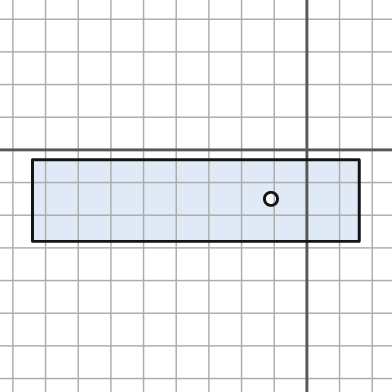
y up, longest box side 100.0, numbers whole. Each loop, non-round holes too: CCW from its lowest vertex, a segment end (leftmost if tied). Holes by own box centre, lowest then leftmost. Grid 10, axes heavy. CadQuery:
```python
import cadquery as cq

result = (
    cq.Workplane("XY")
    .moveTo(-84.0, -28.0)
    .lineTo(16.0, -28.0)
    .lineTo(16.0, -3.0)
    .lineTo(-84.0, -3.0)
    .close()
    .moveTo(-11.0, -15.0)
    .circle(2.0)
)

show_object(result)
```